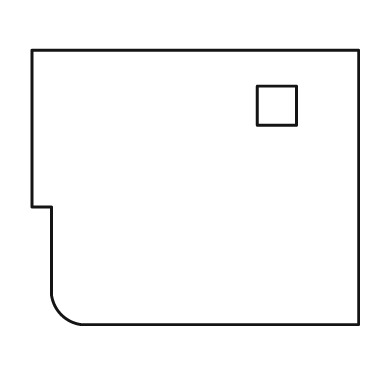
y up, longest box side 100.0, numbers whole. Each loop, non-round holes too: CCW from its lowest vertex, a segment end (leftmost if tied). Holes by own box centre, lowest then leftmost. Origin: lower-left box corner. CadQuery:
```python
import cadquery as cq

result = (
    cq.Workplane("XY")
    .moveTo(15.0, 0.0)
    .lineTo(100.0, 0.0)
    .lineTo(100.0, 84.0)
    .lineTo(0.0, 84.0)
    .lineTo(0.0, 36.0)
    .lineTo(6.0, 36.0)
    .lineTo(6.0, 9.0)
    .threePointArc((9.0, 3.0), (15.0, 0.0))
    .close()
    .moveTo(69.0, 61.0)
    .lineTo(81.0, 61.0)
    .lineTo(81.0, 73.0)
    .lineTo(69.0, 73.0)
    .close()
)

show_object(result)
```